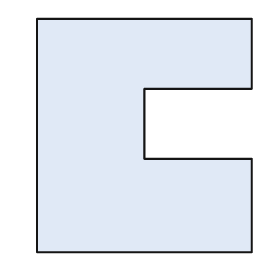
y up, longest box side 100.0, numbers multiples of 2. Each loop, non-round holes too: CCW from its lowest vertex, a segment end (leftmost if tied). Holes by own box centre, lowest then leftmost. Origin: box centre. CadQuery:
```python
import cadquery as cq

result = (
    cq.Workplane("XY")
    .moveTo(-46.0, -50.0)
    .lineTo(46.0, -50.0)
    .lineTo(46.0, -10.0)
    .lineTo(0.0, -10.0)
    .lineTo(0.0, 20.0)
    .lineTo(46.0, 20.0)
    .lineTo(46.0, 50.0)
    .lineTo(-46.0, 50.0)
    .close()
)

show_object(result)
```